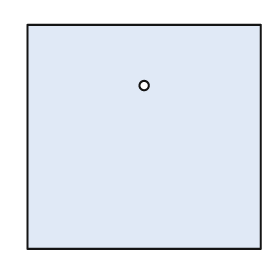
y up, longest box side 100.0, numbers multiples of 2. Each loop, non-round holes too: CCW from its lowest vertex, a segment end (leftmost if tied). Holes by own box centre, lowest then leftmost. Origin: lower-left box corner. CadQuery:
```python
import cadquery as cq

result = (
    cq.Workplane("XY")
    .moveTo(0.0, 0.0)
    .lineTo(100.0, 0.0)
    .lineTo(100.0, 96.0)
    .lineTo(0.0, 96.0)
    .close()
    .moveTo(50.0, 70.0)
    .circle(2.0)
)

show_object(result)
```